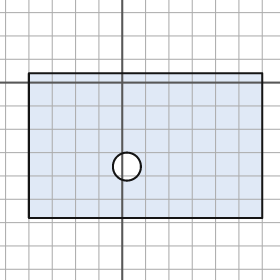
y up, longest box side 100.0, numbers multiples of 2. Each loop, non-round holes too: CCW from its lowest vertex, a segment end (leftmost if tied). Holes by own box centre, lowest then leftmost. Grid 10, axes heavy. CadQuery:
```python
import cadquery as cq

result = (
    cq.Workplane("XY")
    .moveTo(-40.0, -58.0)
    .lineTo(60.0, -58.0)
    .lineTo(60.0, 4.0)
    .lineTo(-40.0, 4.0)
    .close()
    .moveTo(2.0, -36.0)
    .circle(6.0)
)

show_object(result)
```